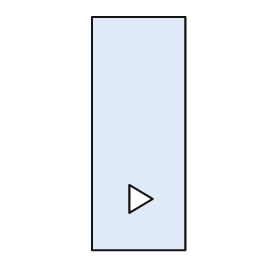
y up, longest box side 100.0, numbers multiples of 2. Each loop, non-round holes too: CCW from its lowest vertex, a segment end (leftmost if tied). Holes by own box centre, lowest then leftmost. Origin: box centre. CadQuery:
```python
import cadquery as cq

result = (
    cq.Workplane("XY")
    .moveTo(-20.0, -50.0)
    .lineTo(20.0, -50.0)
    .lineTo(20.0, 50.0)
    .lineTo(-20.0, 50.0)
    .close()
    .moveTo(-4.0, -34.0)
    .lineTo(6.0, -28.0)
    .lineTo(-4.0, -22.0)
    .close()
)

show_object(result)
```